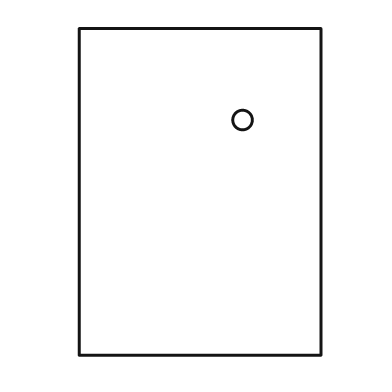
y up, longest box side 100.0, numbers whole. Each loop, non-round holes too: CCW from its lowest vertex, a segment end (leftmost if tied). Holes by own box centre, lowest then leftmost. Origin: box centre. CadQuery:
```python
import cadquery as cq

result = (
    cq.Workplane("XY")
    .moveTo(-37.0, -50.0)
    .lineTo(37.0, -50.0)
    .lineTo(37.0, 50.0)
    .lineTo(-37.0, 50.0)
    .close()
    .moveTo(13.0, 22.0)
    .circle(3.0)
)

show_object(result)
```